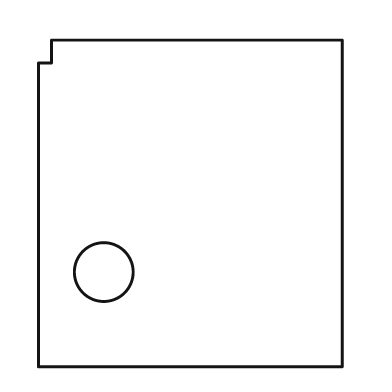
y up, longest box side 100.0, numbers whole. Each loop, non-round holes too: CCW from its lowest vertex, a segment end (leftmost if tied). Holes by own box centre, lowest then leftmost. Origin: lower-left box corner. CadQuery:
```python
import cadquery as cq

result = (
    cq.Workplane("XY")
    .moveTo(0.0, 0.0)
    .lineTo(93.0, 0.0)
    .lineTo(93.0, 100.0)
    .lineTo(4.0, 100.0)
    .lineTo(4.0, 93.0)
    .lineTo(0.0, 93.0)
    .close()
    .moveTo(20.0, 29.0)
    .circle(9.0)
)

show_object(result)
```